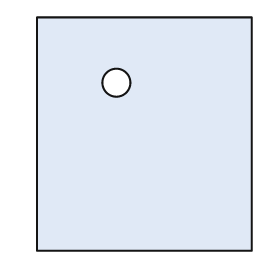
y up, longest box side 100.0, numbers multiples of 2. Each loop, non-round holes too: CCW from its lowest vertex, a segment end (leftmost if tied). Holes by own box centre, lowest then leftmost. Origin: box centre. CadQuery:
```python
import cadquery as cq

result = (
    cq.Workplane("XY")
    .moveTo(-46.0, -50.0)
    .lineTo(46.0, -50.0)
    .lineTo(46.0, 50.0)
    .lineTo(-46.0, 50.0)
    .close()
    .moveTo(-12.0, 22.0)
    .circle(6.0)
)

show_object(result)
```